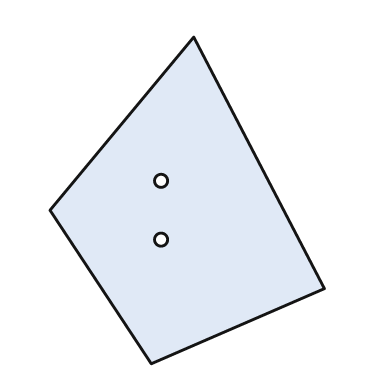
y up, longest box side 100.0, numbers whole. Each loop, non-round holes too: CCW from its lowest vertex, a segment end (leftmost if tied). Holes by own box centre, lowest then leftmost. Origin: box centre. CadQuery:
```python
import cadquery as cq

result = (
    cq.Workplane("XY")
    .moveTo(-11.0, -50.0)
    .lineTo(42.0, -27.0)
    .lineTo(2.0, 50.0)
    .lineTo(-42.0, -3.0)
    .close()
    .moveTo(-8.0, -12.0)
    .circle(2.0)
    .moveTo(-8.0, 6.0)
    .circle(2.0)
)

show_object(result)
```